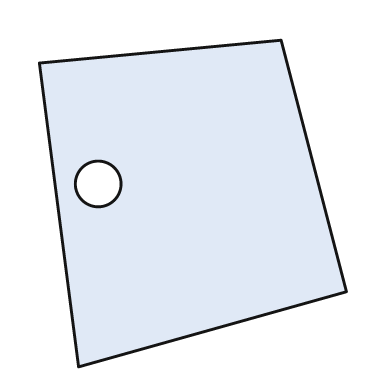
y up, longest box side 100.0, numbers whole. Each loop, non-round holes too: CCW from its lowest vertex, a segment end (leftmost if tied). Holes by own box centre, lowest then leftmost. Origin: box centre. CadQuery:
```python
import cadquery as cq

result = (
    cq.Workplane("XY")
    .moveTo(-35.0, -50.0)
    .lineTo(47.0, -27.0)
    .lineTo(27.0, 50.0)
    .lineTo(-47.0, 43.0)
    .close()
    .moveTo(-29.0, 6.0)
    .circle(7.0)
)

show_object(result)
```